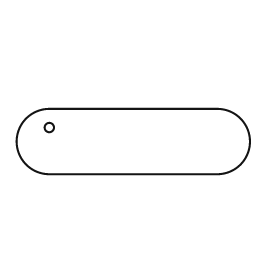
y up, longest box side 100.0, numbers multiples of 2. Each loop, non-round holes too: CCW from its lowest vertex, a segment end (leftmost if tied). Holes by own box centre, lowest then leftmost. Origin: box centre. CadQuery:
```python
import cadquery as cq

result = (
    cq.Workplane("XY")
    .moveTo(-36.0, -14.0)
    .lineTo(36.0, -14.0)
    .threePointArc((50.0, 0.0), (36.0, 14.0))
    .lineTo(-36.0, 14.0)
    .threePointArc((-50.0, 0.0), (-36.0, -14.0))
    .close()
    .moveTo(-36.0, 6.0)
    .circle(2.0)
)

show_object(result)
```